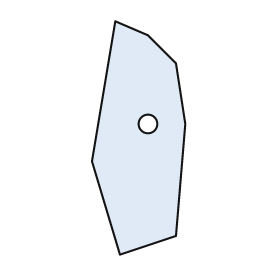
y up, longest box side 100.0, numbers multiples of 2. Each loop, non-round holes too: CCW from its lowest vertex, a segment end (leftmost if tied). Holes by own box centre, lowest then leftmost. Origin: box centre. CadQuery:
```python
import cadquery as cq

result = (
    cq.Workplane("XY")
    .moveTo(-8.0, -50.0)
    .lineTo(16.0, -42.0)
    .lineTo(20.0, 6.0)
    .lineTo(16.0, 32.0)
    .lineTo(4.0, 44.0)
    .lineTo(-10.0, 50.0)
    .lineTo(-20.0, -10.0)
    .close()
    .moveTo(4.0, 6.0)
    .circle(4.0)
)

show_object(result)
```